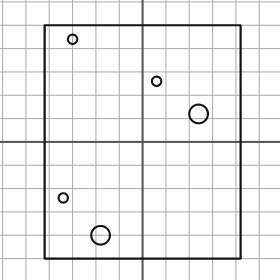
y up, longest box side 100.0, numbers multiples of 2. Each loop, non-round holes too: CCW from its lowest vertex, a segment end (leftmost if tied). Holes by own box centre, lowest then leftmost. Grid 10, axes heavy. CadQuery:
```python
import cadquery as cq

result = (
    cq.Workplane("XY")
    .moveTo(-42.0, -50.0)
    .lineTo(42.0, -50.0)
    .lineTo(42.0, 50.0)
    .lineTo(-42.0, 50.0)
    .close()
    .moveTo(-18.0, -40.0)
    .circle(4.0)
    .moveTo(-34.0, -24.0)
    .circle(2.0)
    .moveTo(24.0, 12.0)
    .circle(4.0)
    .moveTo(6.0, 26.0)
    .circle(2.0)
    .moveTo(-30.0, 44.0)
    .circle(2.0)
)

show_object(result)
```